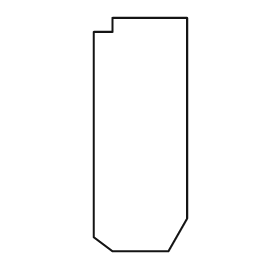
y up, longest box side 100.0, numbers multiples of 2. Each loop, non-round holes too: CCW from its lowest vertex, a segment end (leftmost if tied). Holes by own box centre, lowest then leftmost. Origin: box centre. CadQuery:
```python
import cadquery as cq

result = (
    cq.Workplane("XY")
    .moveTo(-12.0, -50.0)
    .lineTo(12.0, -50.0)
    .lineTo(20.0, -36.0)
    .lineTo(20.0, 50.0)
    .lineTo(-12.0, 50.0)
    .lineTo(-12.0, 44.0)
    .lineTo(-20.0, 44.0)
    .lineTo(-20.0, -44.0)
    .close()
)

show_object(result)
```